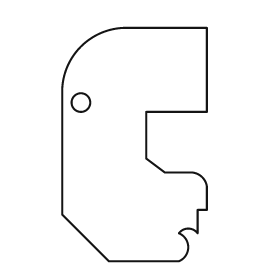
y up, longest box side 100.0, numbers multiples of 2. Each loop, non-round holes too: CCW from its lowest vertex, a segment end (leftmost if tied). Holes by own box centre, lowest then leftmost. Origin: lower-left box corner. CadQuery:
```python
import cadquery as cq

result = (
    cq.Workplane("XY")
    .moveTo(20.0, 0.0)
    .lineTo(50.0, 0.0)
    .threePointArc((54.0, 6.0), (50.0, 12.0))
    .threePointArc((54.0, 14.0), (58.0, 12.0))
    .lineTo(58.0, 22.0)
    .lineTo(62.0, 22.0)
    .lineTo(62.0, 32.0)
    .threePointArc((60.0, 36.0), (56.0, 38.0))
    .lineTo(44.0, 38.0)
    .lineTo(36.0, 44.0)
    .lineTo(36.0, 64.0)
    .lineTo(62.0, 64.0)
    .lineTo(62.0, 100.0)
    .lineTo(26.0, 100.0)
    .threePointArc((8.0, 92.0), (0.0, 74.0))
    .lineTo(0.0, 20.0)
    .close()
    .moveTo(8.0, 68.0)
    .circle(4.0)
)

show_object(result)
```